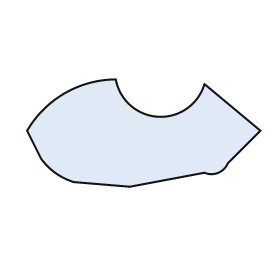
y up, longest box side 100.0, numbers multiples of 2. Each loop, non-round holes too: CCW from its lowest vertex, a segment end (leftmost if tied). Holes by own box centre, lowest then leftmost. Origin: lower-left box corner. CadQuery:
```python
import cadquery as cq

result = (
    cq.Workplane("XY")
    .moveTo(44.0, 0.0)
    .lineTo(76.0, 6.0)
    .threePointArc((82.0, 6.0), (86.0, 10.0))
    .lineTo(100.0, 24.0)
    .lineTo(76.0, 44.0)
    .threePointArc((56.0, 30.0), (38.0, 46.0))
    .threePointArc((16.0, 40.0), (0.0, 24.0))
    .lineTo(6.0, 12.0)
    .threePointArc((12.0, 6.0), (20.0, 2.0))
    .close()
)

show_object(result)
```